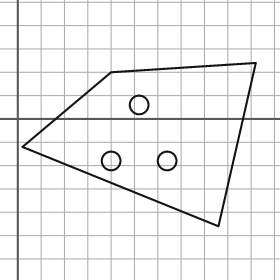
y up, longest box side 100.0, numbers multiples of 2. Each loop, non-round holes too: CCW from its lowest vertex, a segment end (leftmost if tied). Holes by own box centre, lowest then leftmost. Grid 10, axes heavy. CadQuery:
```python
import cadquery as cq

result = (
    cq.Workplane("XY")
    .moveTo(86.0, -46.0)
    .lineTo(102.0, 24.0)
    .lineTo(40.0, 20.0)
    .lineTo(2.0, -12.0)
    .close()
    .moveTo(40.0, -18.0)
    .circle(4.0)
    .moveTo(64.0, -18.0)
    .circle(4.0)
    .moveTo(52.0, 6.0)
    .circle(4.0)
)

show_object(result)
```